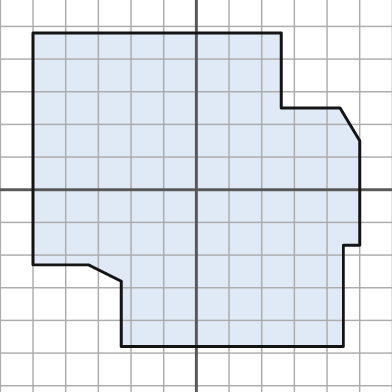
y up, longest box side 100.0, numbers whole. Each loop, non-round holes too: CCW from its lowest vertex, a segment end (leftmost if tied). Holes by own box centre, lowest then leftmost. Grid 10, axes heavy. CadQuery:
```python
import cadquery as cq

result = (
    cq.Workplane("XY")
    .moveTo(-23.0, -48.0)
    .lineTo(45.0, -48.0)
    .lineTo(45.0, -17.0)
    .lineTo(50.0, -17.0)
    .lineTo(50.0, 15.0)
    .lineTo(44.0, 25.0)
    .lineTo(26.0, 25.0)
    .lineTo(26.0, 48.0)
    .lineTo(-50.0, 48.0)
    .lineTo(-50.0, -23.0)
    .lineTo(-33.0, -23.0)
    .lineTo(-23.0, -28.0)
    .close()
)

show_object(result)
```